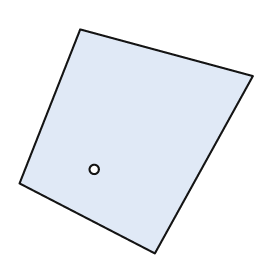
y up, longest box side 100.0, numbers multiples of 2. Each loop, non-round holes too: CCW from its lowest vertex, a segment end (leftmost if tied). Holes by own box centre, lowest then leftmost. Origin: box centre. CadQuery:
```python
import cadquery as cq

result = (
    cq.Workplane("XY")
    .moveTo(8.0, -48.0)
    .lineTo(50.0, 28.0)
    .lineTo(-24.0, 48.0)
    .lineTo(-50.0, -18.0)
    .close()
    .moveTo(-18.0, -12.0)
    .circle(2.0)
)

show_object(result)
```